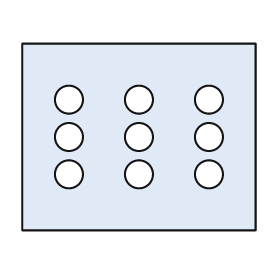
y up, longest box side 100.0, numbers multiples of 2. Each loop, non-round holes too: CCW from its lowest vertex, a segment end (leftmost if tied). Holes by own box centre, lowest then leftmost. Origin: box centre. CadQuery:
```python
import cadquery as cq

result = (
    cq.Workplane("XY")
    .moveTo(-50.0, -40.0)
    .lineTo(50.0, -40.0)
    .lineTo(50.0, 40.0)
    .lineTo(-50.0, 40.0)
    .close()
    .moveTo(-30.0, -16.0)
    .circle(6.0)
    .moveTo(0.0, -16.0)
    .circle(6.0)
    .moveTo(30.0, -16.0)
    .circle(6.0)
    .moveTo(-30.0, 0.0)
    .circle(6.0)
    .moveTo(0.0, 0.0)
    .circle(6.0)
    .moveTo(30.0, 0.0)
    .circle(6.0)
    .moveTo(-30.0, 16.0)
    .circle(6.0)
    .moveTo(0.0, 16.0)
    .circle(6.0)
    .moveTo(30.0, 16.0)
    .circle(6.0)
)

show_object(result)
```